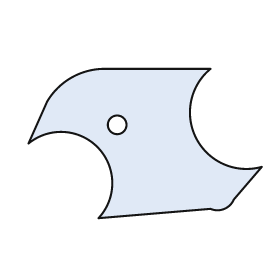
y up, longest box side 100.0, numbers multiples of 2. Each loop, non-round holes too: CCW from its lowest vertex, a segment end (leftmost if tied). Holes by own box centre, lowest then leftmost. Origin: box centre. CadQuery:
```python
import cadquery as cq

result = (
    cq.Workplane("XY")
    .moveTo(-20.0, -32.0)
    .lineTo(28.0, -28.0)
    .threePointArc((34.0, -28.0), (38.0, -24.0))
    .lineTo(50.0, -10.0)
    .threePointArc((22.0, 2.0), (28.0, 32.0))
    .lineTo(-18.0, 32.0)
    .threePointArc((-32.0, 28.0), (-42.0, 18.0))
    .lineTo(-50.0, 0.0)
    .threePointArc((-20.0, -2.0), (-20.0, -32.0))
    .close()
    .moveTo(-12.0, 8.0)
    .circle(4.0)
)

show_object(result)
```